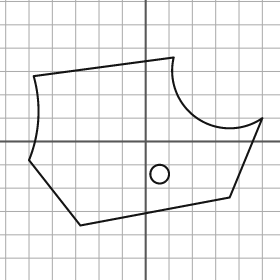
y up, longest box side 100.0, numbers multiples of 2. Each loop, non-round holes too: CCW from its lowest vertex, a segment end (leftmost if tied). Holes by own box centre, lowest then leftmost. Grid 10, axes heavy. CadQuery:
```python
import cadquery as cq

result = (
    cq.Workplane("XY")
    .moveTo(-28.0, -36.0)
    .lineTo(36.0, -24.0)
    .lineTo(50.0, 10.0)
    .threePointArc((22.0, 10.0), (12.0, 36.0))
    .lineTo(-48.0, 28.0)
    .threePointArc((-46.0, 10.0), (-50.0, -8.0))
    .close()
    .moveTo(6.0, -14.0)
    .circle(4.0)
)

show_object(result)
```